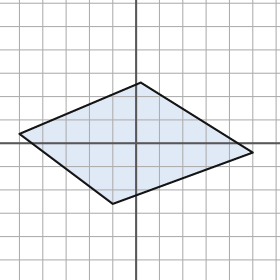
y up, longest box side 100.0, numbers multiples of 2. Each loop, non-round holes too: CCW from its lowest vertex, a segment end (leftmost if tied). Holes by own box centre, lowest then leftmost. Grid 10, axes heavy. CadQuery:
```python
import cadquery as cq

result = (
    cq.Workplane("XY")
    .moveTo(-10.0, -26.0)
    .lineTo(50.0, -4.0)
    .lineTo(2.0, 26.0)
    .lineTo(-50.0, 4.0)
    .close()
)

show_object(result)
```